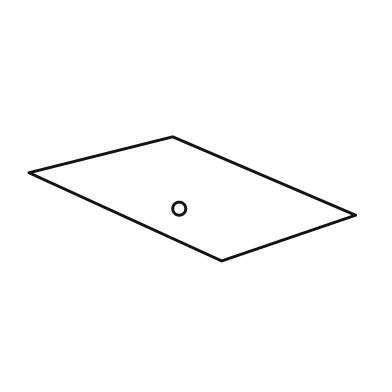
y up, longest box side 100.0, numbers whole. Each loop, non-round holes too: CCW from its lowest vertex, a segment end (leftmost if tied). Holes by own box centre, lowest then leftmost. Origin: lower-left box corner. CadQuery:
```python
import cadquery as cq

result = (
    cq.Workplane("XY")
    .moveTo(59.0, 0.0)
    .lineTo(100.0, 14.0)
    .lineTo(44.0, 38.0)
    .lineTo(0.0, 27.0)
    .close()
    .moveTo(46.0, 16.0)
    .circle(2.0)
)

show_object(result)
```